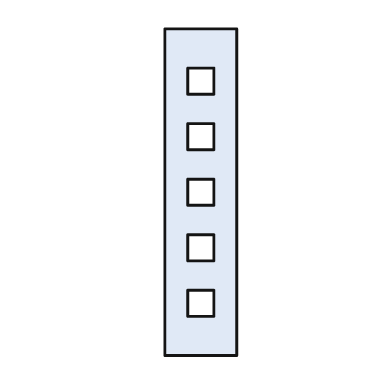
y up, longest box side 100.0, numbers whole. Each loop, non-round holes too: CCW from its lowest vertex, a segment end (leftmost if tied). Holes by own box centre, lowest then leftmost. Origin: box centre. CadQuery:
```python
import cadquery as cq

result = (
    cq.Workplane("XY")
    .moveTo(-11.0, -50.0)
    .lineTo(11.0, -50.0)
    .lineTo(11.0, 50.0)
    .lineTo(-11.0, 50.0)
    .close()
    .moveTo(-4.0, -38.0)
    .lineTo(4.0, -38.0)
    .lineTo(4.0, -30.0)
    .lineTo(-4.0, -30.0)
    .close()
    .moveTo(-4.0, -21.0)
    .lineTo(4.0, -21.0)
    .lineTo(4.0, -13.0)
    .lineTo(-4.0, -13.0)
    .close()
    .moveTo(-4.0, -4.0)
    .lineTo(4.0, -4.0)
    .lineTo(4.0, 4.0)
    .lineTo(-4.0, 4.0)
    .close()
    .moveTo(-4.0, 13.0)
    .lineTo(4.0, 13.0)
    .lineTo(4.0, 21.0)
    .lineTo(-4.0, 21.0)
    .close()
    .moveTo(-4.0, 30.0)
    .lineTo(4.0, 30.0)
    .lineTo(4.0, 38.0)
    .lineTo(-4.0, 38.0)
    .close()
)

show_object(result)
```